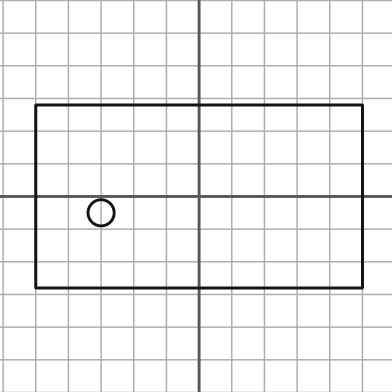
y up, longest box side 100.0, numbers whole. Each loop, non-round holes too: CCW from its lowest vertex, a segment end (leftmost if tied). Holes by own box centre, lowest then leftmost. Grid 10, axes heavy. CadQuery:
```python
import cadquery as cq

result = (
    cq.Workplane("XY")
    .moveTo(-50.0, -28.0)
    .lineTo(50.0, -28.0)
    .lineTo(50.0, 28.0)
    .lineTo(-50.0, 28.0)
    .close()
    .moveTo(-30.0, -5.0)
    .circle(4.0)
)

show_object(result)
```